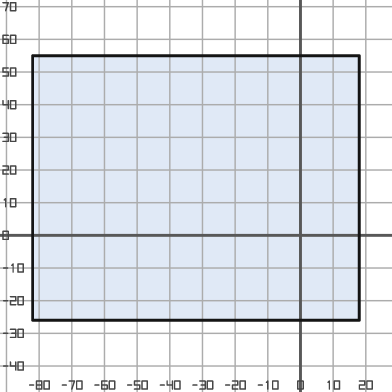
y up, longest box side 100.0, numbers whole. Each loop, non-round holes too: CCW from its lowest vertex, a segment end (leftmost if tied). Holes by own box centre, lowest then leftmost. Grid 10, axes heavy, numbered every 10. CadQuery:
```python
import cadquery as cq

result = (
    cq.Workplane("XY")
    .moveTo(-82.0, -26.0)
    .lineTo(18.0, -26.0)
    .lineTo(18.0, 55.0)
    .lineTo(-82.0, 55.0)
    .close()
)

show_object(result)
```